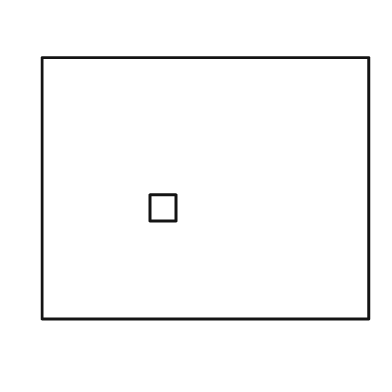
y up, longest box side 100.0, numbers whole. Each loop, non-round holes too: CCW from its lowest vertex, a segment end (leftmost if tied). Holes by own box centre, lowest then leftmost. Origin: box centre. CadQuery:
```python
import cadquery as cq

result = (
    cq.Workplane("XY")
    .moveTo(-50.0, -40.0)
    .lineTo(50.0, -40.0)
    .lineTo(50.0, 40.0)
    .lineTo(-50.0, 40.0)
    .close()
    .moveTo(-17.0, -10.0)
    .lineTo(-9.0, -10.0)
    .lineTo(-9.0, -2.0)
    .lineTo(-17.0, -2.0)
    .close()
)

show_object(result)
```